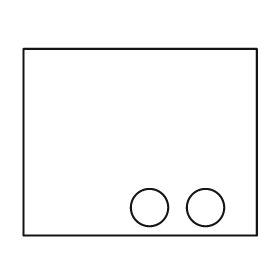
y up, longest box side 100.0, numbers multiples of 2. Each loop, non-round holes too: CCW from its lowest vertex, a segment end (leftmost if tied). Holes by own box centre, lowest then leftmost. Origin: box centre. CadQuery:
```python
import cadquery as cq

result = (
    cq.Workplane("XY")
    .moveTo(-50.0, -40.0)
    .lineTo(50.0, -40.0)
    .lineTo(50.0, 40.0)
    .lineTo(-50.0, 40.0)
    .close()
    .moveTo(4.0, -28.0)
    .circle(8.0)
    .moveTo(28.0, -28.0)
    .circle(8.0)
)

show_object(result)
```